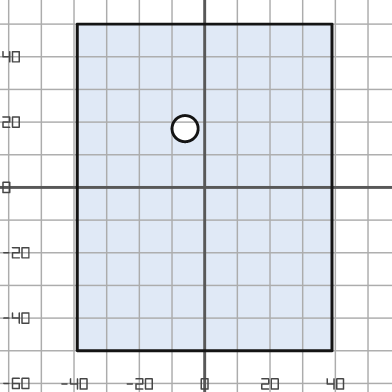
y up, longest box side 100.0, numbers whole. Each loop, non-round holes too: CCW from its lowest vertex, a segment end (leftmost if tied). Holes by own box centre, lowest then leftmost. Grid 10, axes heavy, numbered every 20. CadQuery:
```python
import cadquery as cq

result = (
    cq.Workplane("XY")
    .moveTo(-39.0, -50.0)
    .lineTo(39.0, -50.0)
    .lineTo(39.0, 50.0)
    .lineTo(-39.0, 50.0)
    .close()
    .moveTo(-6.0, 18.0)
    .circle(4.0)
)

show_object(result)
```